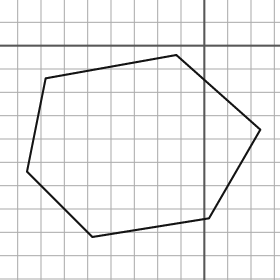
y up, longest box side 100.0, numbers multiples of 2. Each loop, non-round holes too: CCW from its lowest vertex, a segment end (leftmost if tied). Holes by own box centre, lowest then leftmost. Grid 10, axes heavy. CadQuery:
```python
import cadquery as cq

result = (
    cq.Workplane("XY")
    .moveTo(-48.0, -82.0)
    .lineTo(2.0, -74.0)
    .lineTo(24.0, -36.0)
    .lineTo(-12.0, -4.0)
    .lineTo(-68.0, -14.0)
    .lineTo(-76.0, -54.0)
    .close()
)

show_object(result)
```